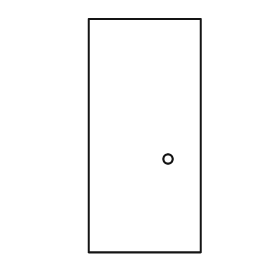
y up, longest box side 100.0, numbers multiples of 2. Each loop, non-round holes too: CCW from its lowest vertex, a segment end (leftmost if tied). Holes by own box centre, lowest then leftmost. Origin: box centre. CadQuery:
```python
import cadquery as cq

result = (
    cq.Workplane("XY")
    .moveTo(-24.0, -50.0)
    .lineTo(24.0, -50.0)
    .lineTo(24.0, 50.0)
    .lineTo(-24.0, 50.0)
    .close()
    .moveTo(10.0, -10.0)
    .circle(2.0)
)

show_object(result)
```